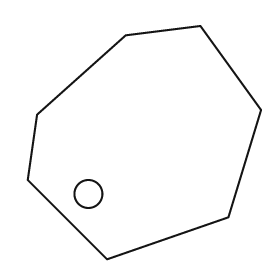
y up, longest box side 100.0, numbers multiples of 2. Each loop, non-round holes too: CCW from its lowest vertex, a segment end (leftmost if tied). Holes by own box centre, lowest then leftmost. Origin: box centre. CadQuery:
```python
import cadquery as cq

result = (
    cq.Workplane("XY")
    .moveTo(-16.0, -50.0)
    .lineTo(36.0, -32.0)
    .lineTo(50.0, 14.0)
    .lineTo(24.0, 50.0)
    .lineTo(-8.0, 46.0)
    .lineTo(-46.0, 12.0)
    .lineTo(-50.0, -16.0)
    .close()
    .moveTo(-24.0, -22.0)
    .circle(6.0)
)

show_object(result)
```